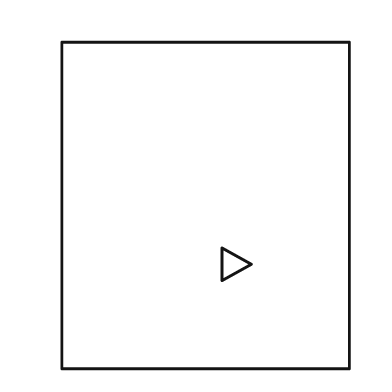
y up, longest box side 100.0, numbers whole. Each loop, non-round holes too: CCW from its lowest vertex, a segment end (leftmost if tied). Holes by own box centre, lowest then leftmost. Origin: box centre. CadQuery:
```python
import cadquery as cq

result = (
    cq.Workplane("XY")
    .moveTo(-44.0, -50.0)
    .lineTo(44.0, -50.0)
    .lineTo(44.0, 50.0)
    .lineTo(-44.0, 50.0)
    .close()
    .moveTo(5.0, -23.0)
    .lineTo(14.0, -18.0)
    .lineTo(5.0, -13.0)
    .close()
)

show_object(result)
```